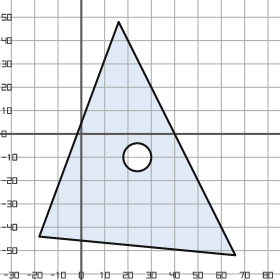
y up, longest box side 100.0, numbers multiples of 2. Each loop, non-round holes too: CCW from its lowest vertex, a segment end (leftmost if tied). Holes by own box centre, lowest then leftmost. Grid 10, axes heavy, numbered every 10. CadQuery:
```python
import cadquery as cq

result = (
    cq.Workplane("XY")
    .moveTo(66.0, -52.0)
    .lineTo(16.0, 48.0)
    .lineTo(-18.0, -44.0)
    .close()
    .moveTo(24.0, -10.0)
    .circle(6.0)
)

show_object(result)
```